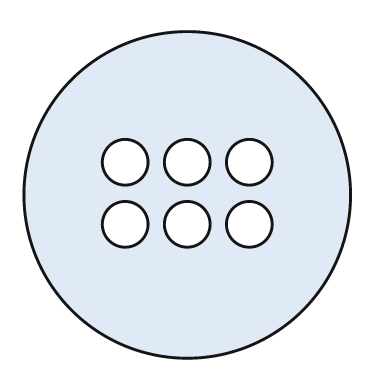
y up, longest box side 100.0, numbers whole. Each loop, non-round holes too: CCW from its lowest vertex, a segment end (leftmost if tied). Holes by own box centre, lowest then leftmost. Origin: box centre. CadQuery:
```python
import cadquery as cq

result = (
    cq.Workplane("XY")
    .moveTo(0.0, 0.0)
    .circle(50.0)
    .moveTo(-19.0, -9.0)
    .circle(7.0)
    .moveTo(0.0, -9.0)
    .circle(7.0)
    .moveTo(19.0, -9.0)
    .circle(7.0)
    .moveTo(-19.0, 10.0)
    .circle(7.0)
    .moveTo(0.0, 10.0)
    .circle(7.0)
    .moveTo(19.0, 10.0)
    .circle(7.0)
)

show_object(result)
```